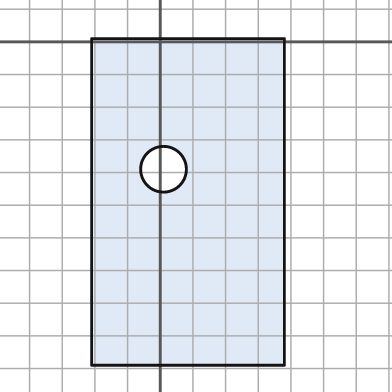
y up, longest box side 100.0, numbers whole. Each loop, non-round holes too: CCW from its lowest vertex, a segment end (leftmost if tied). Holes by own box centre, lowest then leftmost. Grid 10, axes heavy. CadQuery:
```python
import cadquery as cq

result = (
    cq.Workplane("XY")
    .moveTo(-21.0, -99.0)
    .lineTo(38.0, -99.0)
    .lineTo(38.0, 1.0)
    .lineTo(-21.0, 1.0)
    .close()
    .moveTo(1.0, -39.0)
    .circle(7.0)
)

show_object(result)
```